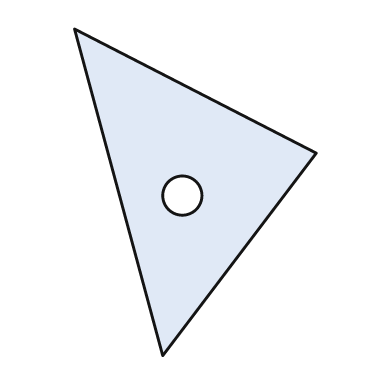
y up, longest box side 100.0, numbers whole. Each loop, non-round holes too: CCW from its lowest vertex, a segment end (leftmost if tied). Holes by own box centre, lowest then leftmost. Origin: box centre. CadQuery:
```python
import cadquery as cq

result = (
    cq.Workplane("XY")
    .moveTo(-10.0, -50.0)
    .lineTo(37.0, 12.0)
    .lineTo(-37.0, 50.0)
    .close()
    .moveTo(-4.0, -1.0)
    .circle(6.0)
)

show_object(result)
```